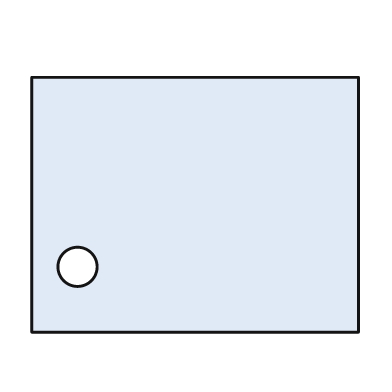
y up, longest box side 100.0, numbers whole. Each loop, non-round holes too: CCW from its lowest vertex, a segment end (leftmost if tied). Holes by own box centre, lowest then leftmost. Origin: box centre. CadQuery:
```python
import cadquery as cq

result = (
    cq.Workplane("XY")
    .moveTo(-50.0, -39.0)
    .lineTo(50.0, -39.0)
    .lineTo(50.0, 39.0)
    .lineTo(-50.0, 39.0)
    .close()
    .moveTo(-36.0, -19.0)
    .circle(6.0)
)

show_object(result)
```